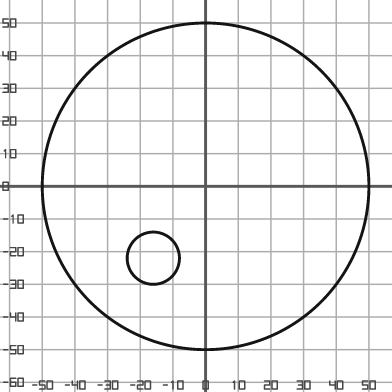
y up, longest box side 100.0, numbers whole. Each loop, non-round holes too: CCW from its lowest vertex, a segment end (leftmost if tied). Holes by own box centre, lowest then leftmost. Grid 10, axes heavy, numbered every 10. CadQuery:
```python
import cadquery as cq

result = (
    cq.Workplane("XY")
    .moveTo(0.0, 0.0)
    .circle(50.0)
    .moveTo(-16.0, -22.0)
    .circle(8.0)
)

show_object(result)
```